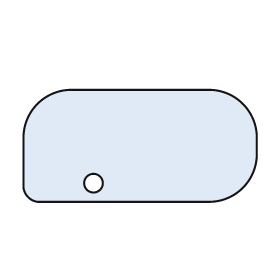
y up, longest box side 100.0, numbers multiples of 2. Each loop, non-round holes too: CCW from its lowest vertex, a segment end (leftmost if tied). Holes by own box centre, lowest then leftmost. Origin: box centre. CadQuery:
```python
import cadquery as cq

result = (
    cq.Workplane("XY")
    .moveTo(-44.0, -24.0)
    .lineTo(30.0, -24.0)
    .threePointArc((44.0, -18.0), (50.0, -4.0))
    .lineTo(50.0, 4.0)
    .threePointArc((44.0, 18.0), (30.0, 24.0))
    .lineTo(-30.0, 24.0)
    .threePointArc((-44.0, 18.0), (-50.0, 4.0))
    .lineTo(-50.0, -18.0)
    .threePointArc((-48.0, -22.0), (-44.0, -24.0))
    .close()
    .moveTo(-20.0, -16.0)
    .circle(4.0)
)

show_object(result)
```